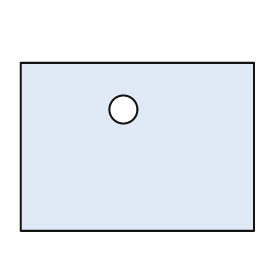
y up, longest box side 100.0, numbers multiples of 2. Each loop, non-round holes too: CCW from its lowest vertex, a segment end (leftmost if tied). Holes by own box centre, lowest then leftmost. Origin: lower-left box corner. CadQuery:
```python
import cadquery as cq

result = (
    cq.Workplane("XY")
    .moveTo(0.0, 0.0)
    .lineTo(100.0, 0.0)
    .lineTo(100.0, 72.0)
    .lineTo(0.0, 72.0)
    .close()
    .moveTo(44.0, 52.0)
    .circle(6.0)
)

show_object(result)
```